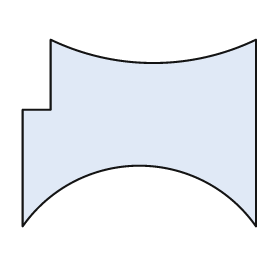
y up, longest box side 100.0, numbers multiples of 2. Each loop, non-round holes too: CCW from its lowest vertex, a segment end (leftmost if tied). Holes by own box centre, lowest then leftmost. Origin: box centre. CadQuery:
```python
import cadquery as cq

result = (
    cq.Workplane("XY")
    .moveTo(-50.0, -40.0)
    .threePointArc((0.0, -14.0), (50.0, -40.0))
    .lineTo(50.0, 40.0)
    .threePointArc((6.0, 30.0), (-38.0, 40.0))
    .lineTo(-38.0, 10.0)
    .lineTo(-50.0, 10.0)
    .close()
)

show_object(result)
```